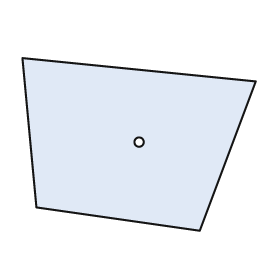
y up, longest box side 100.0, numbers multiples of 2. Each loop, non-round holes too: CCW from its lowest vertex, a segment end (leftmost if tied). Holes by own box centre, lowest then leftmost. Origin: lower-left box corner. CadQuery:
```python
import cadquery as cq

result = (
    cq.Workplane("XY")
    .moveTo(76.0, 0.0)
    .lineTo(100.0, 64.0)
    .lineTo(0.0, 74.0)
    .lineTo(6.0, 10.0)
    .close()
    .moveTo(50.0, 38.0)
    .circle(2.0)
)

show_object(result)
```